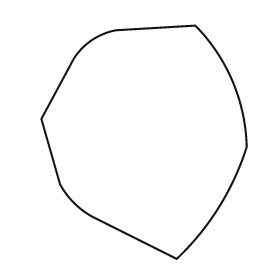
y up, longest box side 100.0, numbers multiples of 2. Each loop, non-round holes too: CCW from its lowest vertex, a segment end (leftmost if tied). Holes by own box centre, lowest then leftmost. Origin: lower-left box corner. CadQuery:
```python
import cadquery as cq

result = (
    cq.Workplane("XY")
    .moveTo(58.0, 0.0)
    .threePointArc((76.0, 22.0), (88.0, 48.0))
    .threePointArc((82.0, 76.0), (66.0, 100.0))
    .lineTo(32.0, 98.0)
    .threePointArc((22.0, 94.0), (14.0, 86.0))
    .lineTo(0.0, 60.0)
    .lineTo(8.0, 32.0)
    .threePointArc((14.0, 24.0), (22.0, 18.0))
    .close()
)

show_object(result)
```